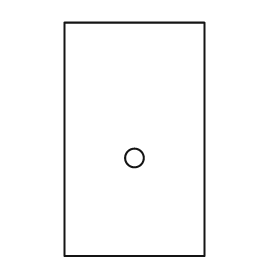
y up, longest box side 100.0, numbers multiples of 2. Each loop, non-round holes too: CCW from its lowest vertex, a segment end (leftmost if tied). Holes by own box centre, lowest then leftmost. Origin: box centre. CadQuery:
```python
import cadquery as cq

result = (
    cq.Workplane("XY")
    .moveTo(-30.0, -50.0)
    .lineTo(30.0, -50.0)
    .lineTo(30.0, 50.0)
    .lineTo(-30.0, 50.0)
    .close()
    .moveTo(0.0, -8.0)
    .circle(4.0)
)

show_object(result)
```